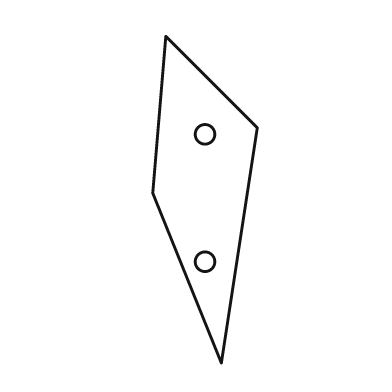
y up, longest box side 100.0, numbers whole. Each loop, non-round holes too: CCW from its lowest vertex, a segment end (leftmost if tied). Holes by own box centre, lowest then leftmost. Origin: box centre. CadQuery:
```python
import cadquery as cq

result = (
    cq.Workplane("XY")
    .moveTo(5.0, -50.0)
    .lineTo(16.0, 22.0)
    .lineTo(-12.0, 50.0)
    .lineTo(-16.0, 2.0)
    .close()
    .moveTo(0.0, -19.0)
    .circle(3.0)
    .moveTo(0.0, 20.0)
    .circle(3.0)
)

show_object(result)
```